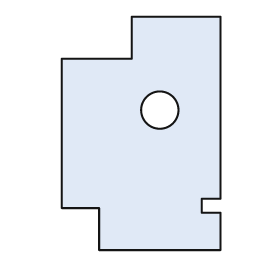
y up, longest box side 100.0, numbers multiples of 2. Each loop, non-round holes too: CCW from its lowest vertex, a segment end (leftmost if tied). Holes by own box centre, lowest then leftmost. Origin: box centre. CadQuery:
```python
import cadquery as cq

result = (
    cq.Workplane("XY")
    .moveTo(-18.0, -50.0)
    .lineTo(34.0, -50.0)
    .lineTo(34.0, -34.0)
    .lineTo(26.0, -34.0)
    .lineTo(26.0, -28.0)
    .lineTo(34.0, -28.0)
    .lineTo(34.0, 50.0)
    .lineTo(-4.0, 50.0)
    .lineTo(-4.0, 32.0)
    .lineTo(-34.0, 32.0)
    .lineTo(-34.0, -32.0)
    .lineTo(-18.0, -32.0)
    .close()
    .moveTo(8.0, 10.0)
    .circle(8.0)
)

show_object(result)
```